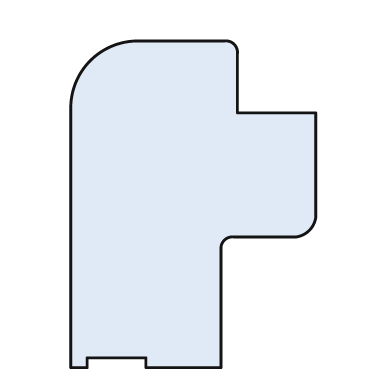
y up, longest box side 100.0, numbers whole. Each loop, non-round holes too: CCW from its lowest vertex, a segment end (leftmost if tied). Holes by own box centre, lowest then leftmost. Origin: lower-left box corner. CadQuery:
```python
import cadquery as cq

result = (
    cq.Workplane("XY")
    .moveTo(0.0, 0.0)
    .lineTo(5.0, 0.0)
    .lineTo(5.0, 3.0)
    .lineTo(23.0, 3.0)
    .lineTo(23.0, 0.0)
    .lineTo(46.0, 0.0)
    .lineTo(46.0, 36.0)
    .threePointArc((47.0, 39.0), (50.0, 40.0))
    .lineTo(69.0, 40.0)
    .threePointArc((73.0, 42.0), (75.0, 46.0))
    .lineTo(75.0, 78.0)
    .lineTo(51.0, 78.0)
    .lineTo(51.0, 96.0)
    .threePointArc((50.0, 99.0), (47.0, 100.0))
    .lineTo(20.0, 100.0)
    .threePointArc((6.0, 94.0), (0.0, 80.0))
    .close()
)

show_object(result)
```